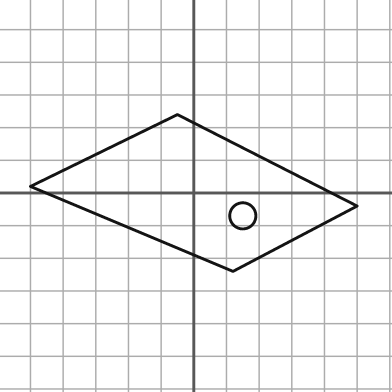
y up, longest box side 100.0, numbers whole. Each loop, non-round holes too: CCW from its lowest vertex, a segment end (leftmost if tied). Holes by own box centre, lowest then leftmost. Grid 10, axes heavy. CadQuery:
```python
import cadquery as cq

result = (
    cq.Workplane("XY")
    .moveTo(12.0, -24.0)
    .lineTo(50.0, -4.0)
    .lineTo(-5.0, 24.0)
    .lineTo(-50.0, 2.0)
    .close()
    .moveTo(15.0, -7.0)
    .circle(4.0)
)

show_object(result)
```